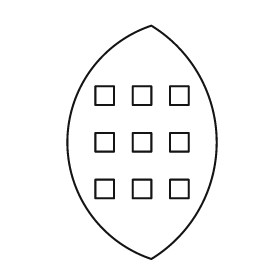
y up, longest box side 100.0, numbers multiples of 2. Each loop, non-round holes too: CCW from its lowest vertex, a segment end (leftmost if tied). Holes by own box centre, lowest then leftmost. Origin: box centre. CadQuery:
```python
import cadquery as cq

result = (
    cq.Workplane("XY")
    .moveTo(4.0, -50.0)
    .threePointArc((32.0, 0.0), (4.0, 50.0))
    .threePointArc((-32.0, 0.0), (4.0, -50.0))
    .close()
    .moveTo(-20.0, -24.0)
    .lineTo(-12.0, -24.0)
    .lineTo(-12.0, -16.0)
    .lineTo(-20.0, -16.0)
    .close()
    .moveTo(-4.0, -24.0)
    .lineTo(4.0, -24.0)
    .lineTo(4.0, -16.0)
    .lineTo(-4.0, -16.0)
    .close()
    .moveTo(12.0, -24.0)
    .lineTo(20.0, -24.0)
    .lineTo(20.0, -16.0)
    .lineTo(12.0, -16.0)
    .close()
    .moveTo(-20.0, -4.0)
    .lineTo(-12.0, -4.0)
    .lineTo(-12.0, 4.0)
    .lineTo(-20.0, 4.0)
    .close()
    .moveTo(-4.0, -4.0)
    .lineTo(4.0, -4.0)
    .lineTo(4.0, 4.0)
    .lineTo(-4.0, 4.0)
    .close()
    .moveTo(12.0, -4.0)
    .lineTo(20.0, -4.0)
    .lineTo(20.0, 4.0)
    .lineTo(12.0, 4.0)
    .close()
    .moveTo(-20.0, 16.0)
    .lineTo(-12.0, 16.0)
    .lineTo(-12.0, 24.0)
    .lineTo(-20.0, 24.0)
    .close()
    .moveTo(-4.0, 16.0)
    .lineTo(4.0, 16.0)
    .lineTo(4.0, 24.0)
    .lineTo(-4.0, 24.0)
    .close()
    .moveTo(12.0, 16.0)
    .lineTo(20.0, 16.0)
    .lineTo(20.0, 24.0)
    .lineTo(12.0, 24.0)
    .close()
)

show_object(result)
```